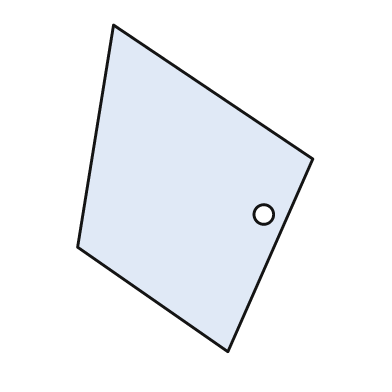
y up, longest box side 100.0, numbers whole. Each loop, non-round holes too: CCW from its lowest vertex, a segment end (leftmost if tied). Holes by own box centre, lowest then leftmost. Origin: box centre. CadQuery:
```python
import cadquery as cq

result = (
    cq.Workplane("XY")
    .moveTo(10.0, -50.0)
    .lineTo(36.0, 9.0)
    .lineTo(-25.0, 50.0)
    .lineTo(-36.0, -18.0)
    .close()
    .moveTo(21.0, -8.0)
    .circle(3.0)
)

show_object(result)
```